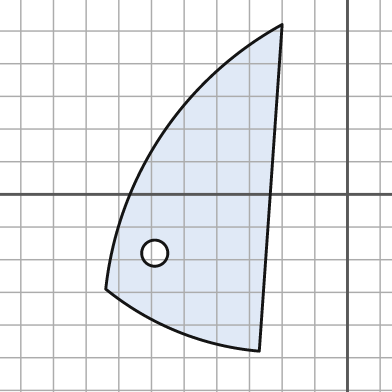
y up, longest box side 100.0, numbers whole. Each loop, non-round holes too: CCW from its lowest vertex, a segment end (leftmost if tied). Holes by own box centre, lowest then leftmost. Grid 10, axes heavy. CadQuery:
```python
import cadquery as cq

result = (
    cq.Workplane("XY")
    .moveTo(-27.0, -48.0)
    .lineTo(-20.0, 52.0)
    .threePointArc((-57.0, 18.0), (-74.0, -29.0))
    .threePointArc((-52.0, -42.0), (-27.0, -48.0))
    .close()
    .moveTo(-59.0, -18.0)
    .circle(4.0)
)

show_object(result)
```